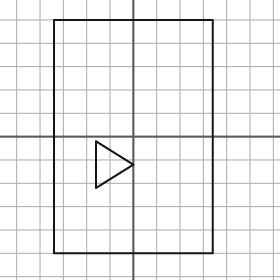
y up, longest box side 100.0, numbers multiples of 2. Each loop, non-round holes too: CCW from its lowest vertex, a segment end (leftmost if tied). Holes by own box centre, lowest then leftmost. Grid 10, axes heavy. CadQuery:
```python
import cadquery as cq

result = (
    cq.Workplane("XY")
    .moveTo(-34.0, -50.0)
    .lineTo(34.0, -50.0)
    .lineTo(34.0, 50.0)
    .lineTo(-34.0, 50.0)
    .close()
    .moveTo(-16.0, -22.0)
    .lineTo(0.0, -12.0)
    .lineTo(-16.0, -2.0)
    .close()
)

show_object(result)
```